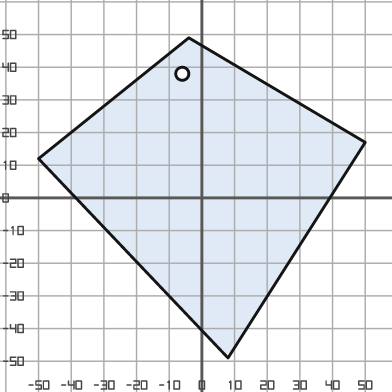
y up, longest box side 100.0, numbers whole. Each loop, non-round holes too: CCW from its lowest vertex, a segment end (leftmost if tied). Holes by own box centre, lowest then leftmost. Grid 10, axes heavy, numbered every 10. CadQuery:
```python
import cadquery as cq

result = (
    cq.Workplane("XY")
    .moveTo(8.0, -49.0)
    .lineTo(50.0, 17.0)
    .lineTo(-4.0, 49.0)
    .lineTo(-50.0, 12.0)
    .close()
    .moveTo(-6.0, 38.0)
    .circle(2.0)
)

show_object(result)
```